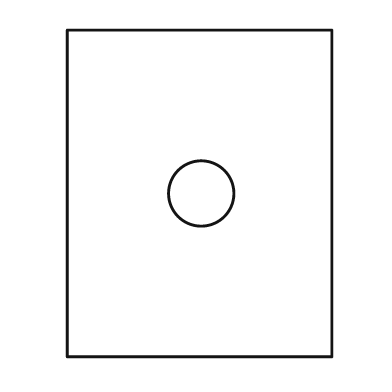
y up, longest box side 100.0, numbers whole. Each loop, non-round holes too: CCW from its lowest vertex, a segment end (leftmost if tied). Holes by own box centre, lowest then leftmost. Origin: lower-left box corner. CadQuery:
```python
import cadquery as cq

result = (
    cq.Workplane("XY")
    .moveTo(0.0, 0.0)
    .lineTo(81.0, 0.0)
    .lineTo(81.0, 100.0)
    .lineTo(0.0, 100.0)
    .close()
    .moveTo(41.0, 50.0)
    .circle(10.0)
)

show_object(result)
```